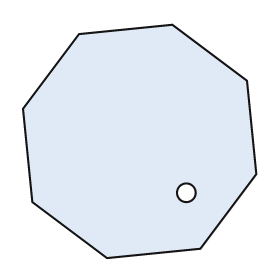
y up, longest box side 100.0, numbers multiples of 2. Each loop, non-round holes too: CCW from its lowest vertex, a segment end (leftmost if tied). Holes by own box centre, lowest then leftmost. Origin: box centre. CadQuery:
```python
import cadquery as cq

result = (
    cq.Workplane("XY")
    .moveTo(-14.0, -50.0)
    .lineTo(26.0, -46.0)
    .lineTo(50.0, -14.0)
    .lineTo(46.0, 26.0)
    .lineTo(14.0, 50.0)
    .lineTo(-26.0, 46.0)
    .lineTo(-50.0, 14.0)
    .lineTo(-46.0, -26.0)
    .close()
    .moveTo(20.0, -22.0)
    .circle(4.0)
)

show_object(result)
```